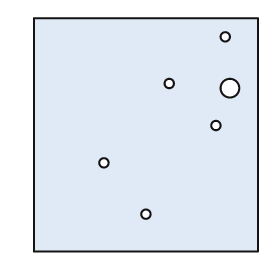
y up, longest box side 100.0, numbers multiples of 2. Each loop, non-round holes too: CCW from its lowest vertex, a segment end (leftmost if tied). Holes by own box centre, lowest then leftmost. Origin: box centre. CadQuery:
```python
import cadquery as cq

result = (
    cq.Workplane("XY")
    .moveTo(-48.0, -50.0)
    .lineTo(48.0, -50.0)
    .lineTo(48.0, 50.0)
    .lineTo(-48.0, 50.0)
    .close()
    .moveTo(0.0, -34.0)
    .circle(2.0)
    .moveTo(-18.0, -12.0)
    .circle(2.0)
    .moveTo(30.0, 4.0)
    .circle(2.0)
    .moveTo(36.0, 20.0)
    .circle(4.0)
    .moveTo(10.0, 22.0)
    .circle(2.0)
    .moveTo(34.0, 42.0)
    .circle(2.0)
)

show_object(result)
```